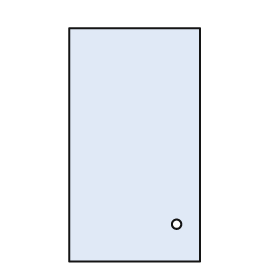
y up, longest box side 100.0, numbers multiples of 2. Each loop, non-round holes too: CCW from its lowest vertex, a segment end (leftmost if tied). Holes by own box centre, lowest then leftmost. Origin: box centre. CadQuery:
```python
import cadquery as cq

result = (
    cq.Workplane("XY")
    .moveTo(-28.0, -50.0)
    .lineTo(28.0, -50.0)
    .lineTo(28.0, 50.0)
    .lineTo(-28.0, 50.0)
    .close()
    .moveTo(18.0, -34.0)
    .circle(2.0)
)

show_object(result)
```